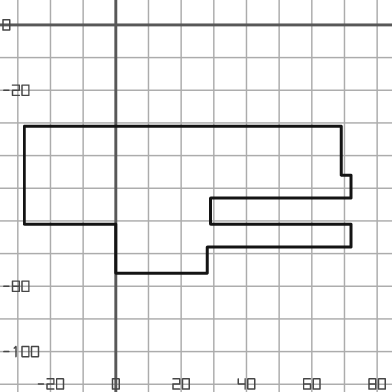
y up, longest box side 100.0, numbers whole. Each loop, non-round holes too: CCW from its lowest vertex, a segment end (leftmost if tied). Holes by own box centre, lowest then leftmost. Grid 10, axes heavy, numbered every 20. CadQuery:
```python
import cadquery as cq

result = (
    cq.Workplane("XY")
    .moveTo(0.0, -76.0)
    .lineTo(28.0, -76.0)
    .lineTo(28.0, -68.0)
    .lineTo(72.0, -68.0)
    .lineTo(72.0, -61.0)
    .lineTo(29.0, -61.0)
    .lineTo(29.0, -53.0)
    .lineTo(72.0, -53.0)
    .lineTo(72.0, -46.0)
    .lineTo(69.0, -46.0)
    .lineTo(69.0, -31.0)
    .lineTo(-28.0, -31.0)
    .lineTo(-28.0, -61.0)
    .lineTo(0.0, -61.0)
    .close()
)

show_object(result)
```